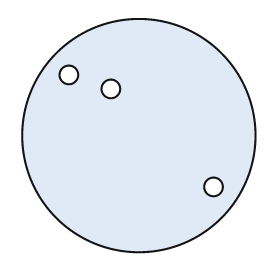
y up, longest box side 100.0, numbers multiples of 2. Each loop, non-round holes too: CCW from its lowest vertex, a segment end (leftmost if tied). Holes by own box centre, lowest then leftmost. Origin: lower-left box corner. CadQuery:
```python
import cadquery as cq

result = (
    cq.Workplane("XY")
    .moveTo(50.0, 50.0)
    .circle(50.0)
    .moveTo(82.0, 28.0)
    .circle(4.0)
    .moveTo(38.0, 70.0)
    .circle(4.0)
    .moveTo(20.0, 76.0)
    .circle(4.0)
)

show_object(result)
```